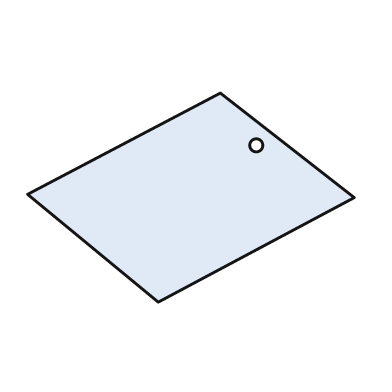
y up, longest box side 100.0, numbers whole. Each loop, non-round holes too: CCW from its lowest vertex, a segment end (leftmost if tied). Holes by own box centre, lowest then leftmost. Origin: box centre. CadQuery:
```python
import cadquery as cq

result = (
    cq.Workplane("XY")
    .moveTo(-10.0, -32.0)
    .lineTo(50.0, 0.0)
    .lineTo(9.0, 32.0)
    .lineTo(-50.0, 1.0)
    .close()
    .moveTo(20.0, 16.0)
    .circle(2.0)
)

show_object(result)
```